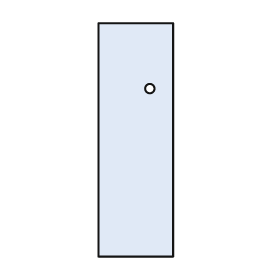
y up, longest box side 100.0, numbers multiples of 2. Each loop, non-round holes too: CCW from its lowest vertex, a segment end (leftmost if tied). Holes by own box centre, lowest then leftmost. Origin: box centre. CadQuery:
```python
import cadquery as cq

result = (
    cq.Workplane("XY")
    .moveTo(-16.0, -50.0)
    .lineTo(16.0, -50.0)
    .lineTo(16.0, 50.0)
    .lineTo(-16.0, 50.0)
    .close()
    .moveTo(6.0, 22.0)
    .circle(2.0)
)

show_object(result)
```